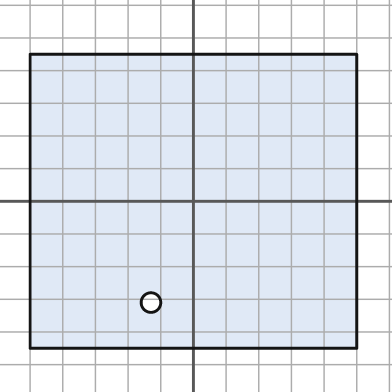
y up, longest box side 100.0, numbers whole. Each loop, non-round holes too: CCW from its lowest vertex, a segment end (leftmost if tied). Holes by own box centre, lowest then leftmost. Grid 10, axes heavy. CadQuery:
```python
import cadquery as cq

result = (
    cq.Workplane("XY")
    .moveTo(-50.0, -45.0)
    .lineTo(50.0, -45.0)
    .lineTo(50.0, 45.0)
    .lineTo(-50.0, 45.0)
    .close()
    .moveTo(-13.0, -31.0)
    .circle(3.0)
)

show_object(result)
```